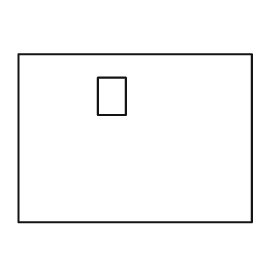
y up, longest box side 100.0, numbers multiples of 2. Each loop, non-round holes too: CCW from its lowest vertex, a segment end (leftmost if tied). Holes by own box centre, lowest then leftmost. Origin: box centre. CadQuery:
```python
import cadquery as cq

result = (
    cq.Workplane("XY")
    .moveTo(-50.0, -36.0)
    .lineTo(50.0, -36.0)
    .lineTo(50.0, 36.0)
    .lineTo(-50.0, 36.0)
    .close()
    .moveTo(-16.0, 10.0)
    .lineTo(-4.0, 10.0)
    .lineTo(-4.0, 26.0)
    .lineTo(-16.0, 26.0)
    .close()
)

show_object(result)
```